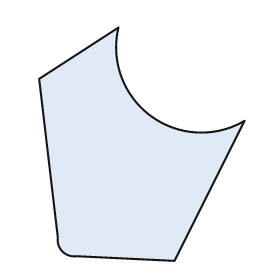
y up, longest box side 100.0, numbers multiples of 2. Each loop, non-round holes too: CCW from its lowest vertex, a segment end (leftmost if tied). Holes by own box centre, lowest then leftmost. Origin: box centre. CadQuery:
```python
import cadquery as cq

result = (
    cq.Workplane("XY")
    .moveTo(14.0, -50.0)
    .lineTo(44.0, 10.0)
    .threePointArc((4.0, 12.0), (-10.0, 50.0))
    .lineTo(-44.0, 28.0)
    .lineTo(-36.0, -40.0)
    .threePointArc((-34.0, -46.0), (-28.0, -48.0))
    .close()
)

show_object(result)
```